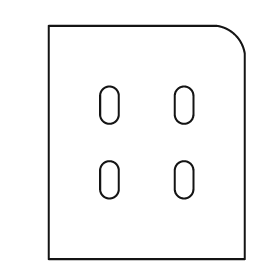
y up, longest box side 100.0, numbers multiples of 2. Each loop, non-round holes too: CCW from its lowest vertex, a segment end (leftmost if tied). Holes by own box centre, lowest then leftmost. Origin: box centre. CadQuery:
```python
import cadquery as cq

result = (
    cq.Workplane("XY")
    .moveTo(-42.0, -50.0)
    .lineTo(42.0, -50.0)
    .lineTo(42.0, 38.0)
    .threePointArc((38.0, 46.0), (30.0, 50.0))
    .lineTo(-42.0, 50.0)
    .close()
    .moveTo(-20.0, -20.0)
    .threePointArc((-16.0, -24.0), (-12.0, -20.0))
    .lineTo(-12.0, -12.0)
    .threePointArc((-16.0, -8.0), (-20.0, -12.0))
    .close()
    .moveTo(12.0, -20.0)
    .threePointArc((16.0, -24.0), (20.0, -20.0))
    .lineTo(20.0, -12.0)
    .threePointArc((16.0, -8.0), (12.0, -12.0))
    .close()
    .moveTo(-20.0, 12.0)
    .threePointArc((-16.0, 8.0), (-12.0, 12.0))
    .lineTo(-12.0, 20.0)
    .threePointArc((-16.0, 24.0), (-20.0, 20.0))
    .close()
    .moveTo(12.0, 12.0)
    .threePointArc((16.0, 8.0), (20.0, 12.0))
    .lineTo(20.0, 20.0)
    .threePointArc((16.0, 24.0), (12.0, 20.0))
    .close()
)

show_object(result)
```